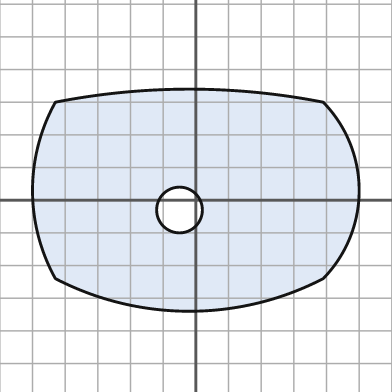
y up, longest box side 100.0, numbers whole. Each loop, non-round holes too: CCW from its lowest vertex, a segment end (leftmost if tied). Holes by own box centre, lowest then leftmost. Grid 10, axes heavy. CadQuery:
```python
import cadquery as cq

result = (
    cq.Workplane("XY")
    .moveTo(-43.0, -24.0)
    .threePointArc((-2.0, -34.0), (39.0, -24.0))
    .threePointArc((50.0, 3.0), (39.0, 30.0))
    .threePointArc((-2.0, 34.0), (-43.0, 30.0))
    .threePointArc((-50.0, 3.0), (-43.0, -24.0))
    .close()
    .moveTo(-5.0, -3.0)
    .circle(7.0)
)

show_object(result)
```